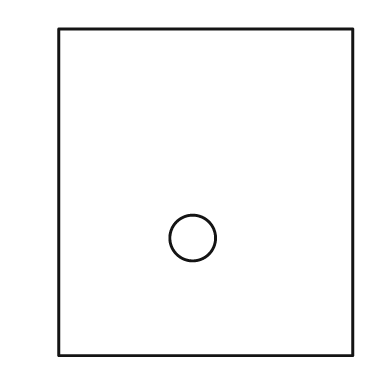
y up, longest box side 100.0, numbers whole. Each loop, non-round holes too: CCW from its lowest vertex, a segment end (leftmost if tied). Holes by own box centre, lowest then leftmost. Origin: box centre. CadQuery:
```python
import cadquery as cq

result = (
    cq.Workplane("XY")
    .moveTo(-45.0, -50.0)
    .lineTo(45.0, -50.0)
    .lineTo(45.0, 50.0)
    .lineTo(-45.0, 50.0)
    .close()
    .moveTo(-4.0, -14.0)
    .circle(7.0)
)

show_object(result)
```